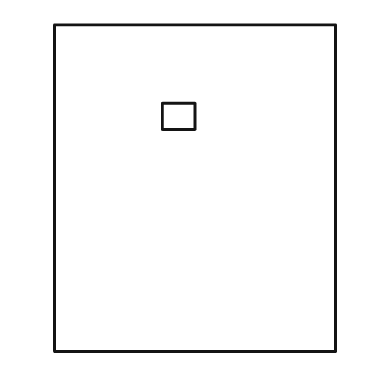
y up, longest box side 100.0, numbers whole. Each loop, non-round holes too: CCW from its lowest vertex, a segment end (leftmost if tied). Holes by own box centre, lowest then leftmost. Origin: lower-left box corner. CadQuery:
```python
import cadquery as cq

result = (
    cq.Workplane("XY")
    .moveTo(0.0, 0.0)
    .lineTo(86.0, 0.0)
    .lineTo(86.0, 100.0)
    .lineTo(0.0, 100.0)
    .close()
    .moveTo(33.0, 68.0)
    .lineTo(43.0, 68.0)
    .lineTo(43.0, 76.0)
    .lineTo(33.0, 76.0)
    .close()
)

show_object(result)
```